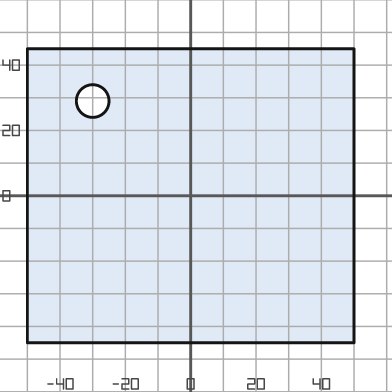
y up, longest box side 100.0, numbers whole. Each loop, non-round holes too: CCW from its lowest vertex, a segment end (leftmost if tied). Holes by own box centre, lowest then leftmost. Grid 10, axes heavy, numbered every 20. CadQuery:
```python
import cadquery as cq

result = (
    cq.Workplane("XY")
    .moveTo(-50.0, -45.0)
    .lineTo(50.0, -45.0)
    .lineTo(50.0, 45.0)
    .lineTo(-50.0, 45.0)
    .close()
    .moveTo(-30.0, 29.0)
    .circle(5.0)
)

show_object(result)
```